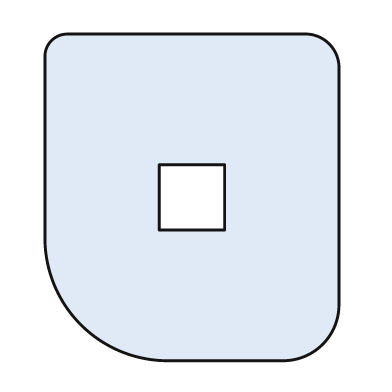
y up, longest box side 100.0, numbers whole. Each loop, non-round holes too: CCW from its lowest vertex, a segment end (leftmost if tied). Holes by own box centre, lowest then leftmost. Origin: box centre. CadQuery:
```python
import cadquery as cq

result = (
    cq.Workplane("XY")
    .moveTo(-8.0, -50.0)
    .lineTo(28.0, -50.0)
    .threePointArc((40.0, -45.0), (45.0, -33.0))
    .lineTo(45.0, 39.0)
    .threePointArc((42.0, 47.0), (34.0, 50.0))
    .lineTo(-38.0, 50.0)
    .threePointArc((-43.0, 48.0), (-45.0, 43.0))
    .lineTo(-45.0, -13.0)
    .threePointArc((-34.0, -39.0), (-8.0, -50.0))
    .close()
    .moveTo(-10.0, -10.0)
    .lineTo(10.0, -10.0)
    .lineTo(10.0, 10.0)
    .lineTo(-10.0, 10.0)
    .close()
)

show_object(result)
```